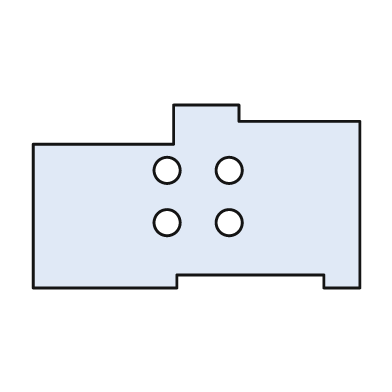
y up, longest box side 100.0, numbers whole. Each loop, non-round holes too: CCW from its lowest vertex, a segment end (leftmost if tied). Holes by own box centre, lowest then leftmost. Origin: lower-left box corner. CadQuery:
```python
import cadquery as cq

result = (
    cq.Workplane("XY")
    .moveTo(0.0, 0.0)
    .lineTo(44.0, 0.0)
    .lineTo(44.0, 4.0)
    .lineTo(89.0, 4.0)
    .lineTo(89.0, 0.0)
    .lineTo(100.0, 0.0)
    .lineTo(100.0, 51.0)
    .lineTo(63.0, 51.0)
    .lineTo(63.0, 56.0)
    .lineTo(43.0, 56.0)
    .lineTo(43.0, 44.0)
    .lineTo(0.0, 44.0)
    .close()
    .moveTo(41.0, 20.0)
    .circle(4.0)
    .moveTo(60.0, 20.0)
    .circle(4.0)
    .moveTo(41.0, 36.0)
    .circle(4.0)
    .moveTo(60.0, 36.0)
    .circle(4.0)
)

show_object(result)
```